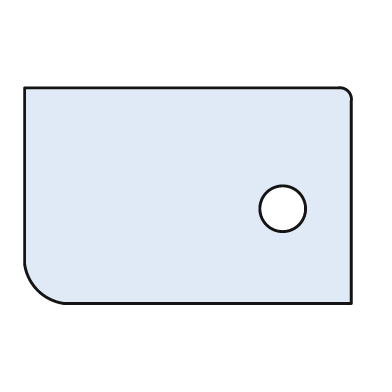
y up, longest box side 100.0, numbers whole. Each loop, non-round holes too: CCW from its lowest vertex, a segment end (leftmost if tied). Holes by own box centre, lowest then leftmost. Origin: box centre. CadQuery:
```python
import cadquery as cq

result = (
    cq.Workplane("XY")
    .moveTo(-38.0, -33.0)
    .lineTo(50.0, -33.0)
    .lineTo(50.0, 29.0)
    .threePointArc((49.0, 32.0), (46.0, 33.0))
    .lineTo(-50.0, 33.0)
    .lineTo(-50.0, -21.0)
    .threePointArc((-46.0, -29.0), (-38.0, -33.0))
    .close()
    .moveTo(29.0, -4.0)
    .circle(7.0)
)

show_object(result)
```